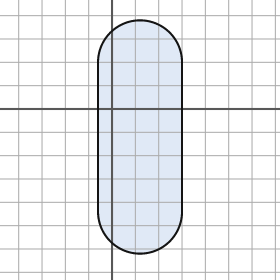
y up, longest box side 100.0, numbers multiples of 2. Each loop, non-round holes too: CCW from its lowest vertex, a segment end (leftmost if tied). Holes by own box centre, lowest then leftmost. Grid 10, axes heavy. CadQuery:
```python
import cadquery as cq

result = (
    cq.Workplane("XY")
    .moveTo(-6.0, -44.0)
    .threePointArc((12.0, -62.0), (30.0, -44.0))
    .lineTo(30.0, 20.0)
    .threePointArc((12.0, 38.0), (-6.0, 20.0))
    .close()
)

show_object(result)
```